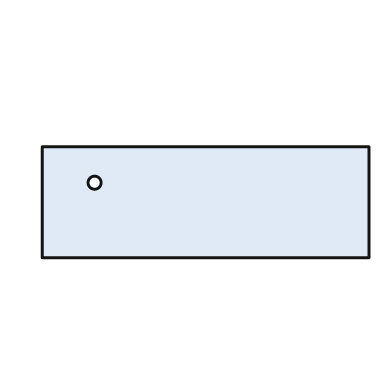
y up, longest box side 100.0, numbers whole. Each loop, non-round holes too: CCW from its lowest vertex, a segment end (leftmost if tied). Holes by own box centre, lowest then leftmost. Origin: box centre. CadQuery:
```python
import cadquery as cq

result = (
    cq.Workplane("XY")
    .moveTo(-50.0, -17.0)
    .lineTo(50.0, -17.0)
    .lineTo(50.0, 17.0)
    .lineTo(-50.0, 17.0)
    .close()
    .moveTo(-34.0, 6.0)
    .circle(2.0)
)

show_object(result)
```